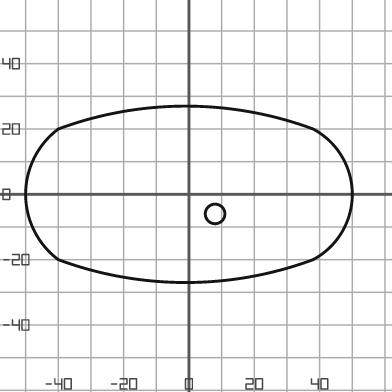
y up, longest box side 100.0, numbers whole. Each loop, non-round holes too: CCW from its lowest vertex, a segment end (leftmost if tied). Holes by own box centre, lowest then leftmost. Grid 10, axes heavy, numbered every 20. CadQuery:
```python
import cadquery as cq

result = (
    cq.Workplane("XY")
    .moveTo(-40.0, -20.0)
    .threePointArc((-1.0, -27.0), (38.0, -20.0))
    .threePointArc((50.0, 0.0), (38.0, 20.0))
    .threePointArc((-1.0, 27.0), (-40.0, 20.0))
    .threePointArc((-50.0, 0.0), (-40.0, -20.0))
    .close()
    .moveTo(8.0, -6.0)
    .circle(3.0)
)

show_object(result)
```